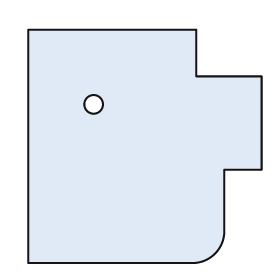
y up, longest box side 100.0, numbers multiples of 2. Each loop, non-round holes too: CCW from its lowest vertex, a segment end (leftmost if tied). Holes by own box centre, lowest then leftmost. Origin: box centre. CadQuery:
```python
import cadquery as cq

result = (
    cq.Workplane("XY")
    .moveTo(-50.0, -50.0)
    .lineTo(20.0, -50.0)
    .threePointArc((30.0, -46.0), (34.0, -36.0))
    .lineTo(34.0, -10.0)
    .lineTo(50.0, -10.0)
    .lineTo(50.0, 30.0)
    .lineTo(22.0, 30.0)
    .lineTo(22.0, 50.0)
    .lineTo(-50.0, 50.0)
    .close()
    .moveTo(-22.0, 18.0)
    .circle(4.0)
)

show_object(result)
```